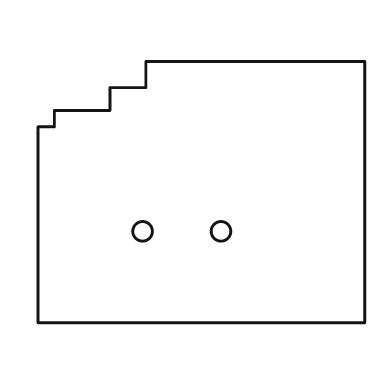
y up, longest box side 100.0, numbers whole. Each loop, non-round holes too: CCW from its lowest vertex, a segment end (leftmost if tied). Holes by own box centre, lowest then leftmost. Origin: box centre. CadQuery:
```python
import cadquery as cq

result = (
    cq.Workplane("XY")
    .moveTo(-50.0, -40.0)
    .lineTo(50.0, -40.0)
    .lineTo(50.0, 40.0)
    .lineTo(-17.0, 40.0)
    .lineTo(-17.0, 32.0)
    .lineTo(-28.0, 32.0)
    .lineTo(-28.0, 25.0)
    .lineTo(-45.0, 25.0)
    .lineTo(-45.0, 20.0)
    .lineTo(-50.0, 20.0)
    .close()
    .moveTo(-18.0, -12.0)
    .circle(3.0)
    .moveTo(6.0, -12.0)
    .circle(3.0)
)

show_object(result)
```